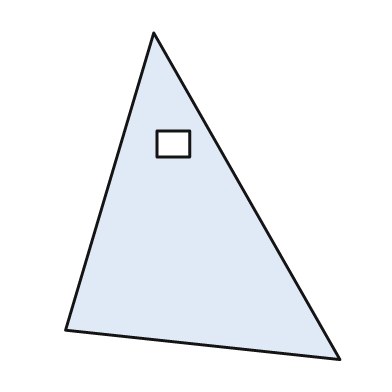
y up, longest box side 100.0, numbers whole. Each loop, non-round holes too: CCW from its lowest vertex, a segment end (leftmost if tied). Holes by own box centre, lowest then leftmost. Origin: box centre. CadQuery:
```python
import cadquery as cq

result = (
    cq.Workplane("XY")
    .moveTo(42.0, -50.0)
    .lineTo(-15.0, 50.0)
    .lineTo(-42.0, -41.0)
    .close()
    .moveTo(-14.0, 12.0)
    .lineTo(-4.0, 12.0)
    .lineTo(-4.0, 20.0)
    .lineTo(-14.0, 20.0)
    .close()
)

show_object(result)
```